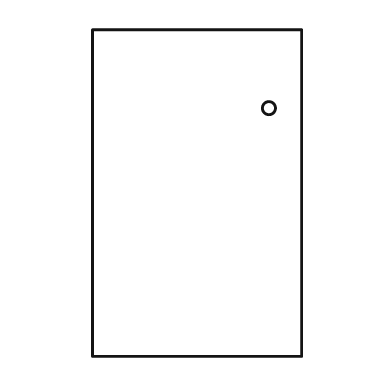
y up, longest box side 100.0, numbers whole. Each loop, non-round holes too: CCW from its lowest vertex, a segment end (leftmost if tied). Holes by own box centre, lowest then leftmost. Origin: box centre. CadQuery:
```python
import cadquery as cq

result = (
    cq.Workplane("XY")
    .moveTo(-32.0, -50.0)
    .lineTo(32.0, -50.0)
    .lineTo(32.0, 50.0)
    .lineTo(-32.0, 50.0)
    .close()
    .moveTo(22.0, 26.0)
    .circle(2.0)
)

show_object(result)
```